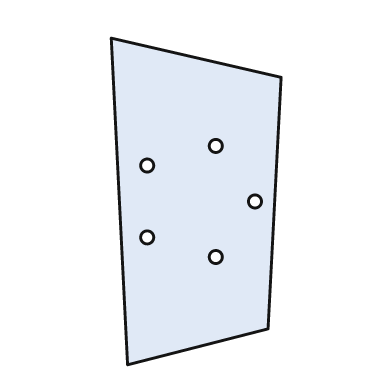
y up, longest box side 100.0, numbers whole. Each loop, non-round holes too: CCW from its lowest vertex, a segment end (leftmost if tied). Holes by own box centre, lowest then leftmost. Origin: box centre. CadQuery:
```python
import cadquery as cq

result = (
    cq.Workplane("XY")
    .moveTo(-21.0, -50.0)
    .lineTo(22.0, -39.0)
    .lineTo(26.0, 38.0)
    .lineTo(-26.0, 50.0)
    .close()
    .moveTo(6.0, -17.0)
    .circle(2.0)
    .moveTo(-15.0, -11.0)
    .circle(2.0)
    .moveTo(18.0, 0.0)
    .circle(2.0)
    .moveTo(-15.0, 11.0)
    .circle(2.0)
    .moveTo(6.0, 17.0)
    .circle(2.0)
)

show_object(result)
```